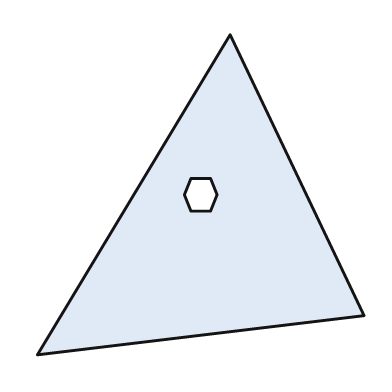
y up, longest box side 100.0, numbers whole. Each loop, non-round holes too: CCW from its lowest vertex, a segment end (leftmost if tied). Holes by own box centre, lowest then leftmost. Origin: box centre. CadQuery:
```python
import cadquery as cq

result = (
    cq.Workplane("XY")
    .moveTo(-50.0, -49.0)
    .lineTo(50.0, -37.0)
    .lineTo(9.0, 49.0)
    .close()
    .moveTo(-3.0, -5.0)
    .lineTo(3.0, -5.0)
    .lineTo(5.0, 0.0)
    .lineTo(3.0, 5.0)
    .lineTo(-3.0, 5.0)
    .lineTo(-5.0, 0.0)
    .close()
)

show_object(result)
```